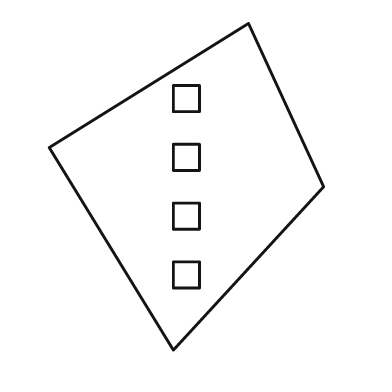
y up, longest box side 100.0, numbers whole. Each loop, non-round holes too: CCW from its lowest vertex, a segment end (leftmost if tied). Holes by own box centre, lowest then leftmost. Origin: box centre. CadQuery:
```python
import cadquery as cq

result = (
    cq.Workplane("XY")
    .moveTo(-4.0, -50.0)
    .lineTo(42.0, 0.0)
    .lineTo(19.0, 50.0)
    .lineTo(-42.0, 12.0)
    .close()
    .moveTo(-4.0, -31.0)
    .lineTo(4.0, -31.0)
    .lineTo(4.0, -23.0)
    .lineTo(-4.0, -23.0)
    .close()
    .moveTo(-4.0, -13.0)
    .lineTo(4.0, -13.0)
    .lineTo(4.0, -5.0)
    .lineTo(-4.0, -5.0)
    .close()
    .moveTo(-4.0, 5.0)
    .lineTo(4.0, 5.0)
    .lineTo(4.0, 13.0)
    .lineTo(-4.0, 13.0)
    .close()
    .moveTo(-4.0, 23.0)
    .lineTo(4.0, 23.0)
    .lineTo(4.0, 31.0)
    .lineTo(-4.0, 31.0)
    .close()
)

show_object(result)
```